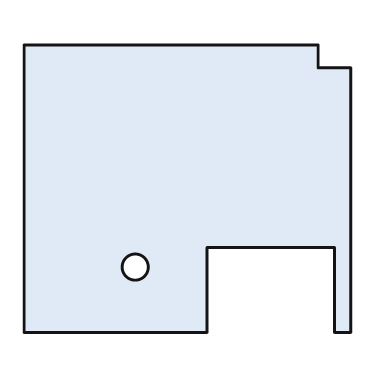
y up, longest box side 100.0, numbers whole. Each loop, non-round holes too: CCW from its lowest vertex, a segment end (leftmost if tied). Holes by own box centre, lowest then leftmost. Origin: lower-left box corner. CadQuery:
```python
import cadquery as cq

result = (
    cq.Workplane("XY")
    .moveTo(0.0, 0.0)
    .lineTo(56.0, 0.0)
    .lineTo(56.0, 26.0)
    .lineTo(95.0, 26.0)
    .lineTo(95.0, 0.0)
    .lineTo(100.0, 0.0)
    .lineTo(100.0, 81.0)
    .lineTo(90.0, 81.0)
    .lineTo(90.0, 88.0)
    .lineTo(0.0, 88.0)
    .close()
    .moveTo(34.0, 20.0)
    .circle(4.0)
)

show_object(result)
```